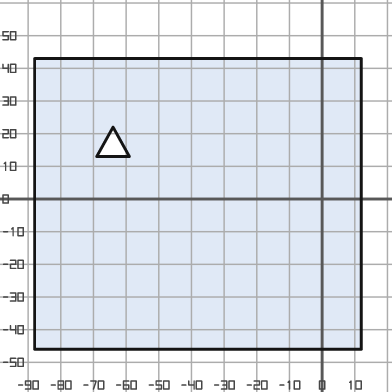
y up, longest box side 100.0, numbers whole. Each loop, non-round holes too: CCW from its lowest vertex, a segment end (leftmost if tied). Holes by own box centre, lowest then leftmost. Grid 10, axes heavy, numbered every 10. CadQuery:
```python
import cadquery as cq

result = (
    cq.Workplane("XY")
    .moveTo(-88.0, -46.0)
    .lineTo(12.0, -46.0)
    .lineTo(12.0, 43.0)
    .lineTo(-88.0, 43.0)
    .close()
    .moveTo(-69.0, 13.0)
    .lineTo(-59.0, 13.0)
    .lineTo(-64.0, 22.0)
    .close()
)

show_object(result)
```